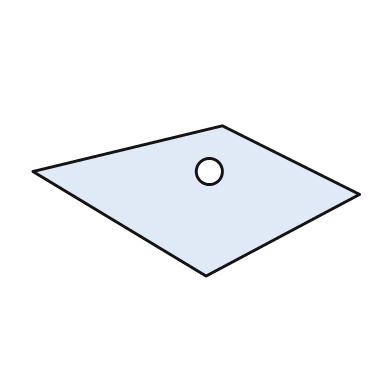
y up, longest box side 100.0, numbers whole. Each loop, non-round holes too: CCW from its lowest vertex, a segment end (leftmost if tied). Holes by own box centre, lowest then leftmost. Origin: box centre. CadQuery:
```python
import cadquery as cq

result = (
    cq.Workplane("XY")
    .moveTo(3.0, -23.0)
    .lineTo(50.0, 2.0)
    .lineTo(8.0, 23.0)
    .lineTo(-50.0, 9.0)
    .close()
    .moveTo(4.0, 9.0)
    .circle(4.0)
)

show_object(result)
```